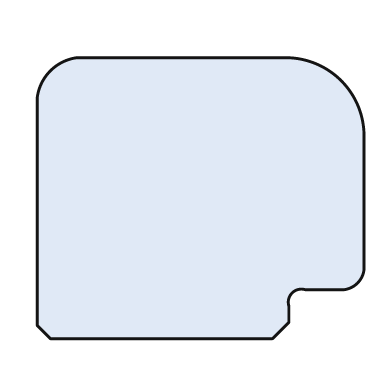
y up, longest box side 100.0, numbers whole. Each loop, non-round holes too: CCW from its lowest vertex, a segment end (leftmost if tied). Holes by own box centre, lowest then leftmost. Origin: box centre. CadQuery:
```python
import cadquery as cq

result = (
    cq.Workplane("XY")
    .moveTo(-46.0, -43.0)
    .lineTo(22.0, -43.0)
    .lineTo(27.0, -38.0)
    .lineTo(27.0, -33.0)
    .threePointArc((28.0, -29.0), (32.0, -28.0))
    .lineTo(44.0, -28.0)
    .threePointArc((48.0, -26.0), (50.0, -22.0))
    .lineTo(50.0, 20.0)
    .threePointArc((43.0, 36.0), (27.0, 43.0))
    .lineTo(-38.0, 43.0)
    .threePointArc((-46.0, 39.0), (-50.0, 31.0))
    .lineTo(-50.0, -39.0)
    .close()
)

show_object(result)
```